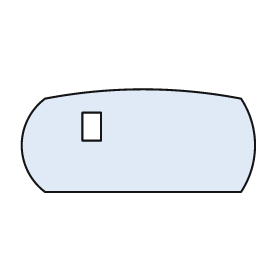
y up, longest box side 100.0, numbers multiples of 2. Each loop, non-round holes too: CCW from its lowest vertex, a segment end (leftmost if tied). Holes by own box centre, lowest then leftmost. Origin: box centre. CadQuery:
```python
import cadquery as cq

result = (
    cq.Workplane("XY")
    .moveTo(-40.0, -22.0)
    .lineTo(44.0, -22.0)
    .threePointArc((50.0, -2.0), (44.0, 18.0))
    .threePointArc((2.0, 22.0), (-40.0, 18.0))
    .threePointArc((-50.0, -2.0), (-40.0, -22.0))
    .close()
    .moveTo(-24.0, 0.0)
    .lineTo(-16.0, 0.0)
    .lineTo(-16.0, 12.0)
    .lineTo(-24.0, 12.0)
    .close()
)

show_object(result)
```